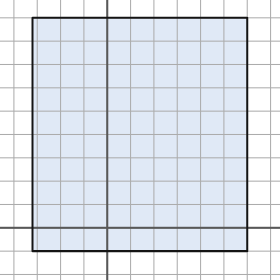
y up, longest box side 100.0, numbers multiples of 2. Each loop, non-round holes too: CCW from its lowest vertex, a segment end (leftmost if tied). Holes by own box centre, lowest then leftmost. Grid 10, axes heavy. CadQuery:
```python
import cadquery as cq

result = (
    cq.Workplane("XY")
    .moveTo(-32.0, -10.0)
    .lineTo(60.0, -10.0)
    .lineTo(60.0, 90.0)
    .lineTo(-32.0, 90.0)
    .close()
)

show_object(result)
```